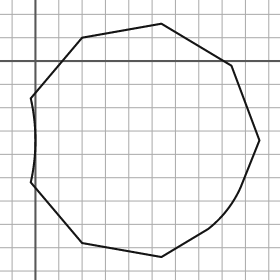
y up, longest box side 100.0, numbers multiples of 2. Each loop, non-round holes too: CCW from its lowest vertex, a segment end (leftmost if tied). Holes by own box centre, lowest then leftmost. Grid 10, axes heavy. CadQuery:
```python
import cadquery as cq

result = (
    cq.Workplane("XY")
    .moveTo(54.0, -84.0)
    .lineTo(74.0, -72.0)
    .threePointArc((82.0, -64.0), (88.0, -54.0))
    .lineTo(96.0, -34.0)
    .lineTo(84.0, -2.0)
    .lineTo(54.0, 16.0)
    .lineTo(20.0, 10.0)
    .lineTo(-2.0, -16.0)
    .threePointArc((0.0, -34.0), (-2.0, -52.0))
    .lineTo(20.0, -78.0)
    .close()
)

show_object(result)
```